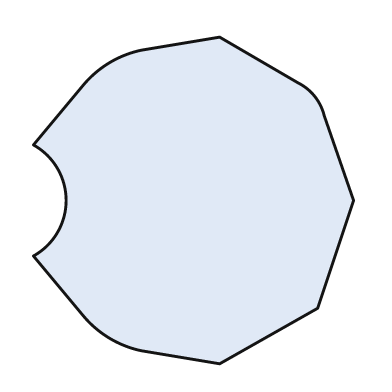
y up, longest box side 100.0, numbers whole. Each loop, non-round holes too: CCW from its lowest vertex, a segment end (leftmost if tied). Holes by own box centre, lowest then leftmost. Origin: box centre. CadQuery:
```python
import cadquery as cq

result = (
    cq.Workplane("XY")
    .moveTo(8.0, -50.0)
    .lineTo(38.0, -33.0)
    .lineTo(49.0, 0.0)
    .lineTo(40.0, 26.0)
    .threePointArc((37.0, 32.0), (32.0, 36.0))
    .lineTo(8.0, 50.0)
    .lineTo(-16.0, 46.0)
    .threePointArc((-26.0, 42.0), (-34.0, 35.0))
    .lineTo(-49.0, 17.0)
    .threePointArc((-39.0, 0.0), (-49.0, -17.0))
    .lineTo(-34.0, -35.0)
    .threePointArc((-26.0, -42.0), (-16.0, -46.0))
    .close()
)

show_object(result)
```